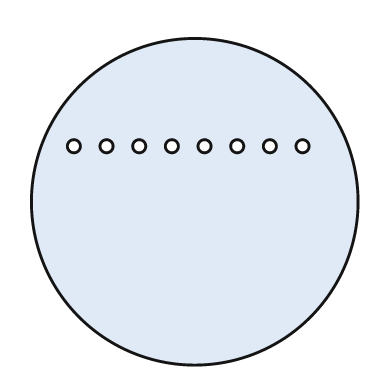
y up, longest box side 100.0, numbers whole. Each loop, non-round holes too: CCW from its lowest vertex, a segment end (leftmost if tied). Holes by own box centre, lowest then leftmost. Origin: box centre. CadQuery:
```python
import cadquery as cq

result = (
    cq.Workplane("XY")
    .moveTo(0.0, 0.0)
    .circle(50.0)
    .moveTo(-37.0, 17.0)
    .circle(2.0)
    .moveTo(-27.0, 17.0)
    .circle(2.0)
    .moveTo(-17.0, 17.0)
    .circle(2.0)
    .moveTo(-7.0, 17.0)
    .circle(2.0)
    .moveTo(3.0, 17.0)
    .circle(2.0)
    .moveTo(13.0, 17.0)
    .circle(2.0)
    .moveTo(23.0, 17.0)
    .circle(2.0)
    .moveTo(33.0, 17.0)
    .circle(2.0)
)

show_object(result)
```